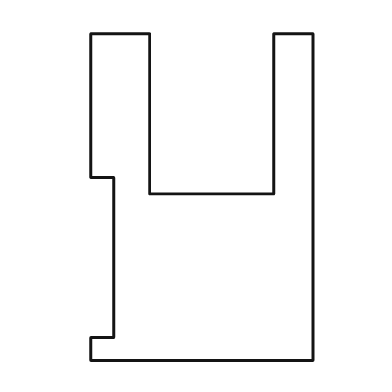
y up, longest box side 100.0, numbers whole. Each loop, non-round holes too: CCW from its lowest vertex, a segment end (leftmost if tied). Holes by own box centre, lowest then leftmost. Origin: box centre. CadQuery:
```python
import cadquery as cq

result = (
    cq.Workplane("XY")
    .moveTo(-34.0, -50.0)
    .lineTo(34.0, -50.0)
    .lineTo(34.0, 50.0)
    .lineTo(22.0, 50.0)
    .lineTo(22.0, 1.0)
    .lineTo(-16.0, 1.0)
    .lineTo(-16.0, 50.0)
    .lineTo(-34.0, 50.0)
    .lineTo(-34.0, 6.0)
    .lineTo(-27.0, 6.0)
    .lineTo(-27.0, -43.0)
    .lineTo(-34.0, -43.0)
    .close()
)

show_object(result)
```